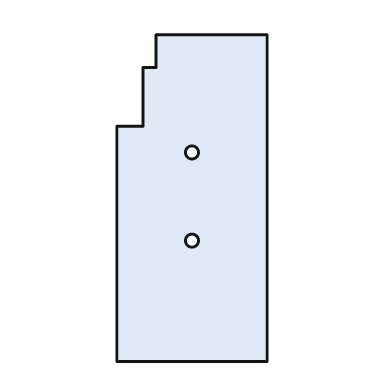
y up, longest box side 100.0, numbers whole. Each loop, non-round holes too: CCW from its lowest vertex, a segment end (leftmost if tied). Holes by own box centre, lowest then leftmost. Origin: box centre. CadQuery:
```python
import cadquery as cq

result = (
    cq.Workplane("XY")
    .moveTo(-23.0, -50.0)
    .lineTo(23.0, -50.0)
    .lineTo(23.0, 50.0)
    .lineTo(-11.0, 50.0)
    .lineTo(-11.0, 40.0)
    .lineTo(-15.0, 40.0)
    .lineTo(-15.0, 22.0)
    .lineTo(-23.0, 22.0)
    .close()
    .moveTo(0.0, -13.0)
    .circle(2.0)
    .moveTo(0.0, 14.0)
    .circle(2.0)
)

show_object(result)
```